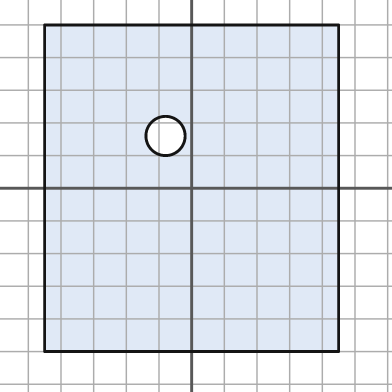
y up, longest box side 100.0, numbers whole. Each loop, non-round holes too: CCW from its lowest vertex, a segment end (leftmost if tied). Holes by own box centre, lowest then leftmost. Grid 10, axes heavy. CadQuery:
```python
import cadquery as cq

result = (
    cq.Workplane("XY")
    .moveTo(-45.0, -50.0)
    .lineTo(45.0, -50.0)
    .lineTo(45.0, 50.0)
    .lineTo(-45.0, 50.0)
    .close()
    .moveTo(-8.0, 16.0)
    .circle(6.0)
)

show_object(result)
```